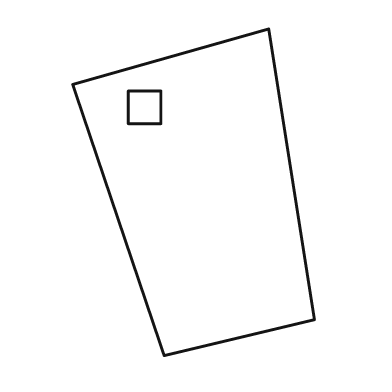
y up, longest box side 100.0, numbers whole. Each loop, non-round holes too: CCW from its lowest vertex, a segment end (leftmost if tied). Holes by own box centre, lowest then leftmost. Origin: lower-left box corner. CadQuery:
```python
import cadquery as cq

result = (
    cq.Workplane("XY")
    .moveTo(28.0, 0.0)
    .lineTo(74.0, 11.0)
    .lineTo(60.0, 100.0)
    .lineTo(0.0, 83.0)
    .close()
    .moveTo(17.0, 71.0)
    .lineTo(27.0, 71.0)
    .lineTo(27.0, 81.0)
    .lineTo(17.0, 81.0)
    .close()
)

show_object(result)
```